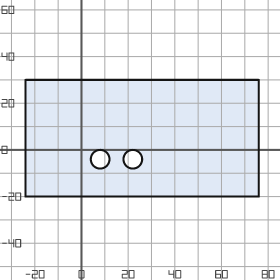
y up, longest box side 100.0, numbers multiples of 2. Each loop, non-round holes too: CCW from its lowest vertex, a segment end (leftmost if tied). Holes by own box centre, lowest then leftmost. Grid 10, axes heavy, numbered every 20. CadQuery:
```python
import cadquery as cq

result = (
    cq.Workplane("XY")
    .moveTo(-24.0, -20.0)
    .lineTo(76.0, -20.0)
    .lineTo(76.0, 30.0)
    .lineTo(-24.0, 30.0)
    .close()
    .moveTo(8.0, -4.0)
    .circle(4.0)
    .moveTo(22.0, -4.0)
    .circle(4.0)
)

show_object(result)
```